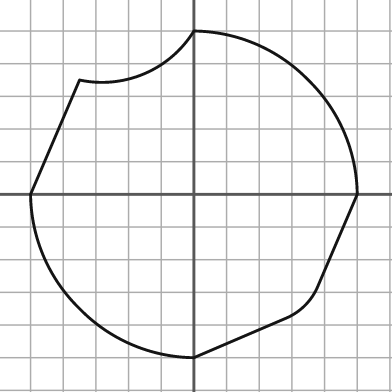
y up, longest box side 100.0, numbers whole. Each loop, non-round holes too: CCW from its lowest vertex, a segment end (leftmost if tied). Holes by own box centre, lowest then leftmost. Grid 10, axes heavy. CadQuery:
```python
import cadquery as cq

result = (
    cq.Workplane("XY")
    .moveTo(0.0, -50.0)
    .lineTo(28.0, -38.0)
    .threePointArc((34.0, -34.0), (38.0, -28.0))
    .lineTo(50.0, 0.0)
    .threePointArc((46.0, 19.0), (35.0, 35.0))
    .threePointArc((19.0, 46.0), (0.0, 50.0))
    .threePointArc((-15.0, 37.0), (-35.0, 35.0))
    .lineTo(-50.0, 0.0)
    .threePointArc((-46.0, -19.0), (-35.0, -35.0))
    .threePointArc((-19.0, -46.0), (0.0, -50.0))
    .close()
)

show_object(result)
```